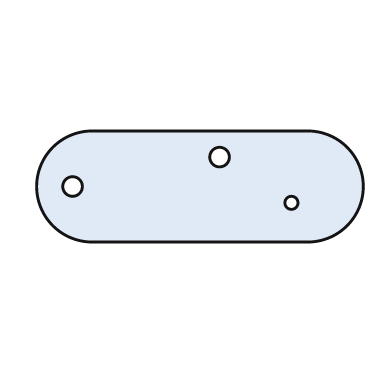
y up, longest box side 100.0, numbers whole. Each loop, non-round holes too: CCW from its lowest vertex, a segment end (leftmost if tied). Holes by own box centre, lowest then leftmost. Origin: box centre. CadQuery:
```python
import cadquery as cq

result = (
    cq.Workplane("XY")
    .moveTo(-33.0, -17.0)
    .lineTo(33.0, -17.0)
    .threePointArc((50.0, 0.0), (33.0, 17.0))
    .lineTo(-33.0, 17.0)
    .threePointArc((-50.0, 0.0), (-33.0, -17.0))
    .close()
    .moveTo(28.0, -5.0)
    .circle(2.0)
    .moveTo(-39.0, 0.0)
    .circle(3.0)
    .moveTo(6.0, 9.0)
    .circle(3.0)
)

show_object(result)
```